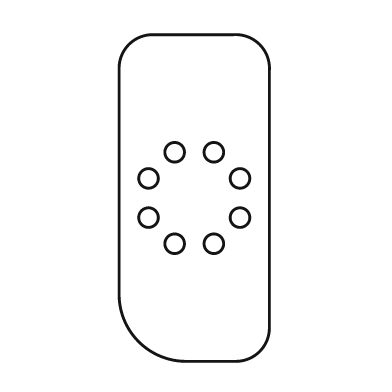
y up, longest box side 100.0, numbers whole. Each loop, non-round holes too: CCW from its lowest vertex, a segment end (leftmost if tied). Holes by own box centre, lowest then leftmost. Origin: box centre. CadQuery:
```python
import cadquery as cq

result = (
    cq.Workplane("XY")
    .moveTo(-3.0, -50.0)
    .lineTo(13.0, -50.0)
    .threePointArc((20.0, -47.0), (23.0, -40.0))
    .lineTo(23.0, 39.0)
    .threePointArc((20.0, 47.0), (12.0, 50.0))
    .lineTo(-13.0, 50.0)
    .threePointArc((-20.0, 47.0), (-23.0, 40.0))
    .lineTo(-23.0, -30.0)
    .threePointArc((-17.0, -44.0), (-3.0, -50.0))
    .close()
    .moveTo(-6.0, -14.0)
    .circle(3.0)
    .moveTo(6.0, -14.0)
    .circle(3.0)
    .moveTo(-14.0, -6.0)
    .circle(3.0)
    .moveTo(14.0, -6.0)
    .circle(3.0)
    .moveTo(-14.0, 6.0)
    .circle(3.0)
    .moveTo(14.0, 6.0)
    .circle(3.0)
    .moveTo(-6.0, 14.0)
    .circle(3.0)
    .moveTo(6.0, 14.0)
    .circle(3.0)
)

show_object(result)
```